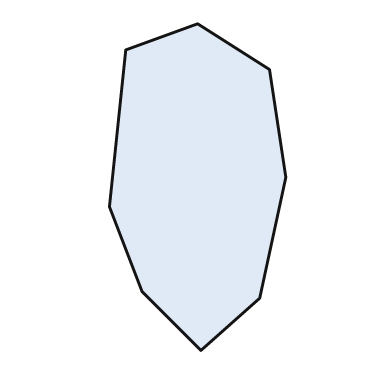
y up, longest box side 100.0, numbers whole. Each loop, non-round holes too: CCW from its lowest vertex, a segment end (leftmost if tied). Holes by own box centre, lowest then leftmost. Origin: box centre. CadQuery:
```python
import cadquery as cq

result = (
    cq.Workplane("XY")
    .moveTo(1.0, -50.0)
    .lineTo(19.0, -34.0)
    .lineTo(27.0, 3.0)
    .lineTo(22.0, 36.0)
    .lineTo(0.0, 50.0)
    .lineTo(-22.0, 42.0)
    .lineTo(-27.0, -6.0)
    .lineTo(-17.0, -32.0)
    .close()
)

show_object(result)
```